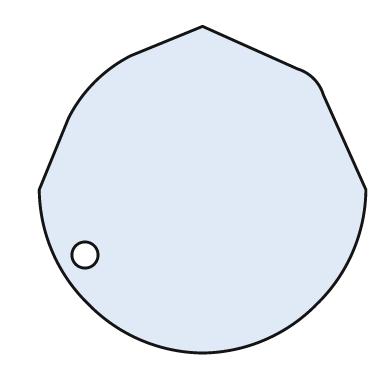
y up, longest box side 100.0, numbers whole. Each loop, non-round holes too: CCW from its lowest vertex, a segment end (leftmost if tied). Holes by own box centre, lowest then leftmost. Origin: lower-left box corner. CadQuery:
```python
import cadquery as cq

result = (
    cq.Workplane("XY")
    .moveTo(50.0, 0.0)
    .threePointArc((69.0, 4.0), (85.0, 15.0))
    .threePointArc((96.0, 31.0), (100.0, 50.0))
    .lineTo(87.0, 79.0)
    .threePointArc((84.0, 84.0), (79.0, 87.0))
    .lineTo(50.0, 100.0)
    .lineTo(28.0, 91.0)
    .threePointArc((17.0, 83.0), (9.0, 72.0))
    .lineTo(0.0, 50.0)
    .threePointArc((4.0, 31.0), (15.0, 15.0))
    .threePointArc((31.0, 4.0), (50.0, 0.0))
    .close()
    .moveTo(14.0, 30.0)
    .circle(4.0)
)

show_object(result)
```